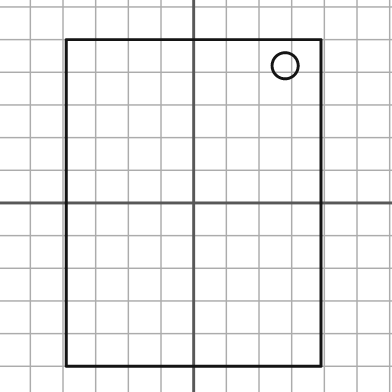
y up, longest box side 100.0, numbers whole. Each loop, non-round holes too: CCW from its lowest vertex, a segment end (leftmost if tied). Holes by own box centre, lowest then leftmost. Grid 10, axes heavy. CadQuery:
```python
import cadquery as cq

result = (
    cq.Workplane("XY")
    .moveTo(-39.0, -50.0)
    .lineTo(39.0, -50.0)
    .lineTo(39.0, 50.0)
    .lineTo(-39.0, 50.0)
    .close()
    .moveTo(28.0, 42.0)
    .circle(4.0)
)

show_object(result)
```